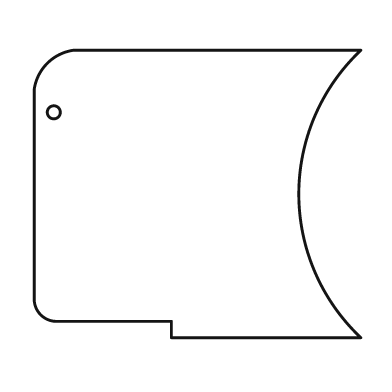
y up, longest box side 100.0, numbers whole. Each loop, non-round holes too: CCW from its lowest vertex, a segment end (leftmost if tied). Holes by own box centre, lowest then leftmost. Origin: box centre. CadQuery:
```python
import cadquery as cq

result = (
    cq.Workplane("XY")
    .moveTo(-8.0, -44.0)
    .lineTo(50.0, -44.0)
    .threePointArc((31.0, 0.0), (50.0, 44.0))
    .lineTo(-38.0, 44.0)
    .threePointArc((-46.0, 40.0), (-50.0, 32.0))
    .lineTo(-50.0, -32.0)
    .threePointArc((-48.0, -37.0), (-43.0, -39.0))
    .lineTo(-8.0, -39.0)
    .close()
    .moveTo(-44.0, 25.0)
    .circle(2.0)
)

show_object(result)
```